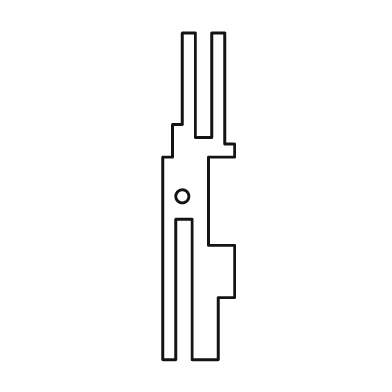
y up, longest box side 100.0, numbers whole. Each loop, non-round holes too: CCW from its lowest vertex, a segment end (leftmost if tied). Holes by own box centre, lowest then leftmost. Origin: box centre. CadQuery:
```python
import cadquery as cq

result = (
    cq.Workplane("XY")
    .moveTo(-11.0, -50.0)
    .lineTo(-7.0, -50.0)
    .lineTo(-7.0, -7.0)
    .lineTo(-2.0, -7.0)
    .lineTo(-2.0, -50.0)
    .lineTo(6.0, -50.0)
    .lineTo(6.0, -31.0)
    .lineTo(11.0, -31.0)
    .lineTo(11.0, -15.0)
    .lineTo(3.0, -15.0)
    .lineTo(3.0, 12.0)
    .lineTo(11.0, 12.0)
    .lineTo(11.0, 16.0)
    .lineTo(8.0, 16.0)
    .lineTo(8.0, 50.0)
    .lineTo(4.0, 50.0)
    .lineTo(4.0, 18.0)
    .lineTo(-1.0, 18.0)
    .lineTo(-1.0, 50.0)
    .lineTo(-5.0, 50.0)
    .lineTo(-5.0, 22.0)
    .lineTo(-8.0, 22.0)
    .lineTo(-8.0, 12.0)
    .lineTo(-11.0, 12.0)
    .close()
    .moveTo(-5.0, 0.0)
    .circle(2.0)
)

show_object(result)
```